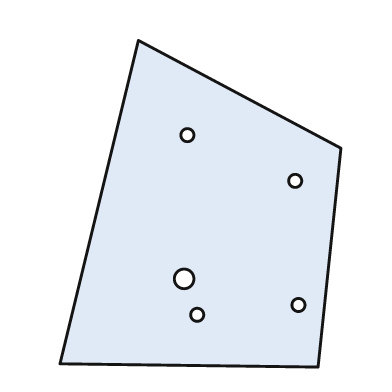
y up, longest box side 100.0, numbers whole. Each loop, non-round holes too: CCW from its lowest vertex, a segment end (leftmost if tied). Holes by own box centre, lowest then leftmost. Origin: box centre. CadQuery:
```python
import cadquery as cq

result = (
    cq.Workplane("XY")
    .moveTo(36.0, -50.0)
    .lineTo(43.0, 17.0)
    .lineTo(-19.0, 50.0)
    .lineTo(-43.0, -49.0)
    .close()
    .moveTo(-1.0, -34.0)
    .circle(2.0)
    .moveTo(30.0, -31.0)
    .circle(2.0)
    .moveTo(-5.0, -23.0)
    .circle(3.0)
    .moveTo(29.0, 7.0)
    .circle(2.0)
    .moveTo(-4.0, 21.0)
    .circle(2.0)
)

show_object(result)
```